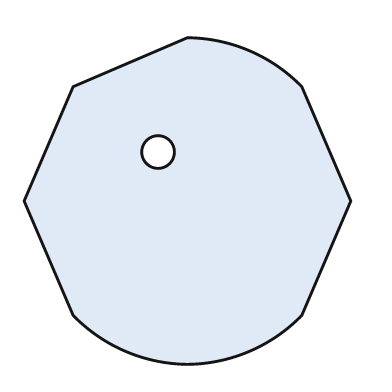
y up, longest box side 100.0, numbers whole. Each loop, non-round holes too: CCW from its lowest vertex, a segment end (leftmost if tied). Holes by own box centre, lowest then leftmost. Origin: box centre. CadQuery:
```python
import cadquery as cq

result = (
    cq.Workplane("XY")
    .moveTo(0.0, -50.0)
    .threePointArc((19.0, -46.0), (35.0, -35.0))
    .lineTo(50.0, 0.0)
    .lineTo(35.0, 35.0)
    .threePointArc((19.0, 46.0), (0.0, 50.0))
    .lineTo(-35.0, 35.0)
    .lineTo(-50.0, 0.0)
    .lineTo(-35.0, -35.0)
    .threePointArc((-19.0, -46.0), (0.0, -50.0))
    .close()
    .moveTo(-9.0, 15.0)
    .circle(5.0)
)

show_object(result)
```